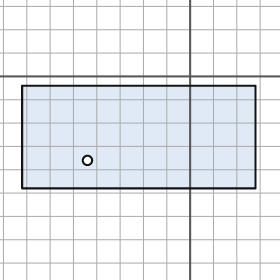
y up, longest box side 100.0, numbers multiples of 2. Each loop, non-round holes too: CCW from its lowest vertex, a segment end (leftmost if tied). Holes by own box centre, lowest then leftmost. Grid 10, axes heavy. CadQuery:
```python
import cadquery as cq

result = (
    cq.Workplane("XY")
    .moveTo(-72.0, -48.0)
    .lineTo(28.0, -48.0)
    .lineTo(28.0, -4.0)
    .lineTo(-72.0, -4.0)
    .close()
    .moveTo(-44.0, -36.0)
    .circle(2.0)
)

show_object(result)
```